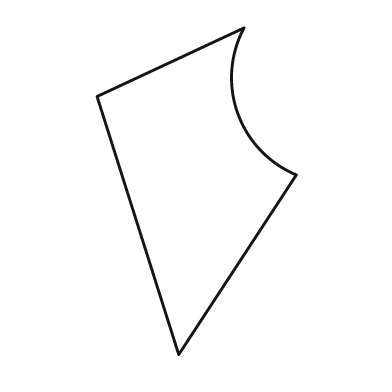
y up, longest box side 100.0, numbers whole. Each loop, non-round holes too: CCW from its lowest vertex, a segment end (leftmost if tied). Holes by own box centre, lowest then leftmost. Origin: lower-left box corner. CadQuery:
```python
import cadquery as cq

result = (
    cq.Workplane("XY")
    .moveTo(25.0, 0.0)
    .lineTo(61.0, 55.0)
    .threePointArc((43.0, 74.0), (45.0, 100.0))
    .lineTo(0.0, 79.0)
    .close()
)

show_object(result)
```